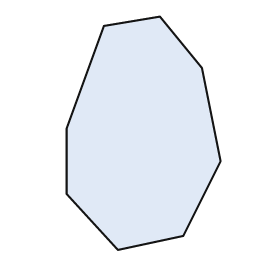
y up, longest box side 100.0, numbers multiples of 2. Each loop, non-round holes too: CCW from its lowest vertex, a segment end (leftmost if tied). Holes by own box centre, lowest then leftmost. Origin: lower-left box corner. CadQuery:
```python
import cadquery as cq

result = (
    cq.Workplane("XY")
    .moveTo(22.0, 0.0)
    .lineTo(50.0, 6.0)
    .lineTo(66.0, 38.0)
    .lineTo(58.0, 78.0)
    .lineTo(40.0, 100.0)
    .lineTo(16.0, 96.0)
    .lineTo(0.0, 52.0)
    .lineTo(0.0, 24.0)
    .close()
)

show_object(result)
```